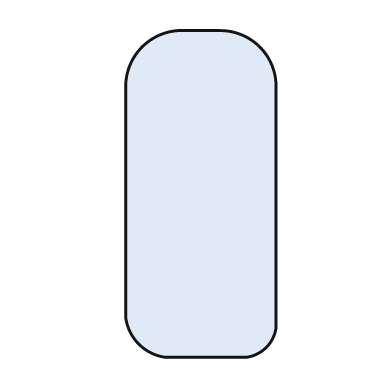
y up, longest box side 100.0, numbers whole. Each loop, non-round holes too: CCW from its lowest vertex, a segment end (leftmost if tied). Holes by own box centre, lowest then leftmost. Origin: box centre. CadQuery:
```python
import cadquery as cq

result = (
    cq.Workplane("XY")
    .moveTo(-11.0, -50.0)
    .lineTo(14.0, -50.0)
    .threePointArc((20.0, -47.0), (23.0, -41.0))
    .lineTo(23.0, 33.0)
    .threePointArc((18.0, 45.0), (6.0, 50.0))
    .lineTo(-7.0, 50.0)
    .threePointArc((-18.0, 45.0), (-23.0, 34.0))
    .lineTo(-23.0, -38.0)
    .threePointArc((-19.0, -46.0), (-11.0, -50.0))
    .close()
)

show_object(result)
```